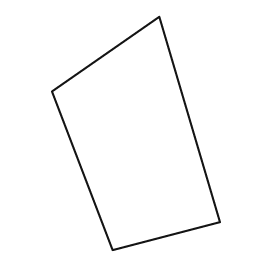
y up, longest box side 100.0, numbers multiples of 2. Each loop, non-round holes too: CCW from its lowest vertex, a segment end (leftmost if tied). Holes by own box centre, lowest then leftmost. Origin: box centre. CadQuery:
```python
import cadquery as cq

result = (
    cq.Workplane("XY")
    .moveTo(-10.0, -50.0)
    .lineTo(36.0, -38.0)
    .lineTo(10.0, 50.0)
    .lineTo(-36.0, 18.0)
    .close()
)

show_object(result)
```